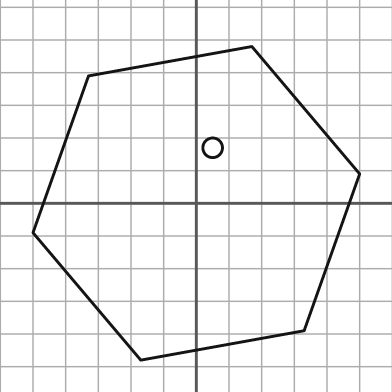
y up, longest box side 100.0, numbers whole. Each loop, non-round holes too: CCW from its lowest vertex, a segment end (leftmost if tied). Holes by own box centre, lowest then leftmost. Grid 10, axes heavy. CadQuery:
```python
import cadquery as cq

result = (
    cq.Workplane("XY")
    .moveTo(-17.0, -48.0)
    .lineTo(33.0, -39.0)
    .lineTo(50.0, 9.0)
    .lineTo(17.0, 48.0)
    .lineTo(-33.0, 39.0)
    .lineTo(-50.0, -9.0)
    .close()
    .moveTo(5.0, 17.0)
    .circle(3.0)
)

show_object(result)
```